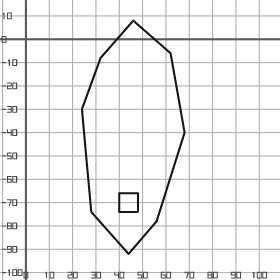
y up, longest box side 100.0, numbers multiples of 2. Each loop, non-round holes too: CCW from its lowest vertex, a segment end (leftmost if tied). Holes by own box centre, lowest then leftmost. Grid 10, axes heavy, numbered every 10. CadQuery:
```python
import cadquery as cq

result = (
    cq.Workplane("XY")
    .moveTo(44.0, -92.0)
    .lineTo(56.0, -78.0)
    .lineTo(68.0, -40.0)
    .lineTo(62.0, -6.0)
    .lineTo(46.0, 8.0)
    .lineTo(32.0, -8.0)
    .lineTo(24.0, -30.0)
    .lineTo(28.0, -74.0)
    .close()
    .moveTo(40.0, -74.0)
    .lineTo(48.0, -74.0)
    .lineTo(48.0, -66.0)
    .lineTo(40.0, -66.0)
    .close()
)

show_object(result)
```